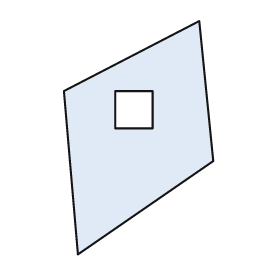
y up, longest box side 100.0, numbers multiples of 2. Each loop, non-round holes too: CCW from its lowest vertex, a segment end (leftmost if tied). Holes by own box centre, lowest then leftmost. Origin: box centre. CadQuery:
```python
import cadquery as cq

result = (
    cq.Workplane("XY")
    .moveTo(-26.0, -50.0)
    .lineTo(32.0, -10.0)
    .lineTo(26.0, 50.0)
    .lineTo(-32.0, 20.0)
    .close()
    .moveTo(-10.0, 4.0)
    .lineTo(6.0, 4.0)
    .lineTo(6.0, 20.0)
    .lineTo(-10.0, 20.0)
    .close()
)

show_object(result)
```